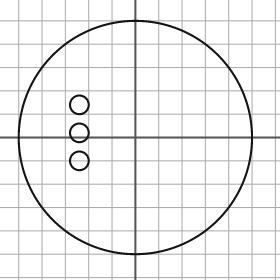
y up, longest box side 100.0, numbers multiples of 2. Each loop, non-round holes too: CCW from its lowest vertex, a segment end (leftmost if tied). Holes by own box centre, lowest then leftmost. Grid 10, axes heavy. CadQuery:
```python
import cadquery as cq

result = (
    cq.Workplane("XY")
    .moveTo(0.0, 0.0)
    .circle(50.0)
    .moveTo(-24.0, -10.0)
    .circle(4.0)
    .moveTo(-24.0, 2.0)
    .circle(4.0)
    .moveTo(-24.0, 14.0)
    .circle(4.0)
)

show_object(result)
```